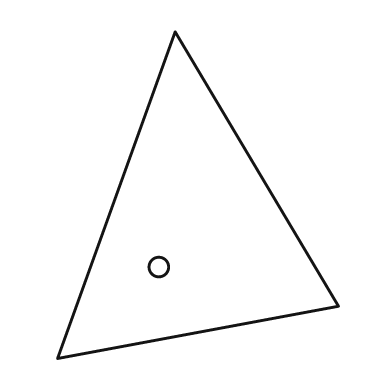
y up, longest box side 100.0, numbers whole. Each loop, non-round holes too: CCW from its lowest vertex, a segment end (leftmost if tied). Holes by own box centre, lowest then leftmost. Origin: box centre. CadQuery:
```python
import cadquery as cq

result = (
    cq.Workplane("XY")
    .moveTo(-43.0, -50.0)
    .lineTo(43.0, -34.0)
    .lineTo(-7.0, 50.0)
    .close()
    .moveTo(-12.0, -22.0)
    .circle(3.0)
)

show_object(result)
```